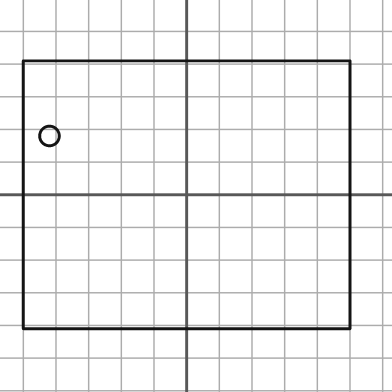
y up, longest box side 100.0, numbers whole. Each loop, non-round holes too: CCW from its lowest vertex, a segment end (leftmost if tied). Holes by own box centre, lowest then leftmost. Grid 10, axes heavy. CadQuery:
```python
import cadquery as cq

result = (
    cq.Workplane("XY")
    .moveTo(-50.0, -41.0)
    .lineTo(50.0, -41.0)
    .lineTo(50.0, 41.0)
    .lineTo(-50.0, 41.0)
    .close()
    .moveTo(-42.0, 18.0)
    .circle(3.0)
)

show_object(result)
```